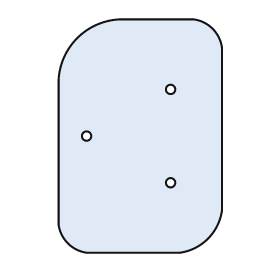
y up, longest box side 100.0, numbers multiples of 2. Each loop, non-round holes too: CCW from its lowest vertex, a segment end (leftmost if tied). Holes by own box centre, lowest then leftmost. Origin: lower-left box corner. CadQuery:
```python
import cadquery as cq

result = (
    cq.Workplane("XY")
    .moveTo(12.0, 0.0)
    .lineTo(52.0, 0.0)
    .threePointArc((64.0, 6.0), (70.0, 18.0))
    .lineTo(70.0, 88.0)
    .threePointArc((66.0, 96.0), (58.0, 100.0))
    .lineTo(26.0, 100.0)
    .threePointArc((8.0, 92.0), (0.0, 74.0))
    .lineTo(0.0, 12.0)
    .threePointArc((4.0, 4.0), (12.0, 0.0))
    .close()
    .moveTo(48.0, 30.0)
    .circle(2.0)
    .moveTo(12.0, 50.0)
    .circle(2.0)
    .moveTo(48.0, 70.0)
    .circle(2.0)
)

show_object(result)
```